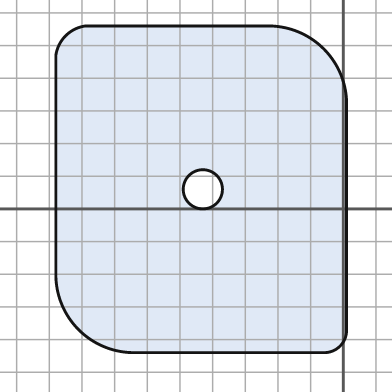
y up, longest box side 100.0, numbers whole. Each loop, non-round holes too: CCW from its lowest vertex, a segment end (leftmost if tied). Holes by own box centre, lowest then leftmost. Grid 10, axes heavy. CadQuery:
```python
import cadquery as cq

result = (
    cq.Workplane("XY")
    .moveTo(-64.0, -44.0)
    .lineTo(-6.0, -44.0)
    .threePointArc((-1.0, -42.0), (1.0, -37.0))
    .lineTo(1.0, 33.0)
    .threePointArc((-6.0, 49.0), (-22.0, 56.0))
    .lineTo(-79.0, 56.0)
    .threePointArc((-85.0, 53.0), (-88.0, 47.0))
    .lineTo(-88.0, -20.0)
    .threePointArc((-81.0, -37.0), (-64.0, -44.0))
    .close()
    .moveTo(-43.0, 6.0)
    .circle(6.0)
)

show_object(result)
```